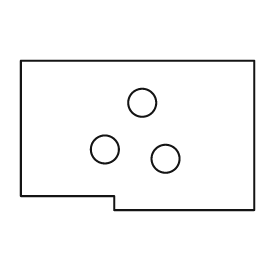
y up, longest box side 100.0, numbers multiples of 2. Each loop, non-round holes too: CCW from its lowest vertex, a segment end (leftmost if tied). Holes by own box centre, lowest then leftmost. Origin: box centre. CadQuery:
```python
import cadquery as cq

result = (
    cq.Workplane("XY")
    .moveTo(-10.0, -32.0)
    .lineTo(50.0, -32.0)
    .lineTo(50.0, 32.0)
    .lineTo(-50.0, 32.0)
    .lineTo(-50.0, -26.0)
    .lineTo(-10.0, -26.0)
    .close()
    .moveTo(12.0, -10.0)
    .circle(6.0)
    .moveTo(-14.0, -6.0)
    .circle(6.0)
    .moveTo(2.0, 14.0)
    .circle(6.0)
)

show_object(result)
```